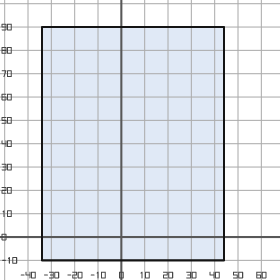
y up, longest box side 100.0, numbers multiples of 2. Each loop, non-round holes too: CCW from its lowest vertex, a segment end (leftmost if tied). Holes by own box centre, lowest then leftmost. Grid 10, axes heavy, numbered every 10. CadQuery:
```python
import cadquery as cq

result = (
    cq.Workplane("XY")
    .moveTo(-34.0, -10.0)
    .lineTo(44.0, -10.0)
    .lineTo(44.0, 90.0)
    .lineTo(-34.0, 90.0)
    .close()
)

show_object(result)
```